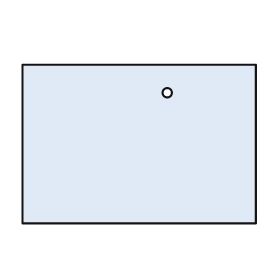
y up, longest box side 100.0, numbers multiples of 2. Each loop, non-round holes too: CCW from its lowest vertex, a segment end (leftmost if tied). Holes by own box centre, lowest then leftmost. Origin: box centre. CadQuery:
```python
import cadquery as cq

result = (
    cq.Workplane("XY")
    .moveTo(-50.0, -34.0)
    .lineTo(50.0, -34.0)
    .lineTo(50.0, 34.0)
    .lineTo(-50.0, 34.0)
    .close()
    .moveTo(12.0, 22.0)
    .circle(2.0)
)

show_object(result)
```